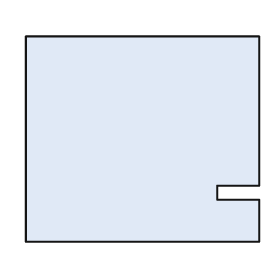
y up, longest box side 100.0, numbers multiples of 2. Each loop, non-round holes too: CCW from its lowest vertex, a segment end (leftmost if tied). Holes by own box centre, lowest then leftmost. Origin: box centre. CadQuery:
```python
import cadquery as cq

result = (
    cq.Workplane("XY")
    .moveTo(-50.0, -44.0)
    .lineTo(50.0, -44.0)
    .lineTo(50.0, -26.0)
    .lineTo(32.0, -26.0)
    .lineTo(32.0, -20.0)
    .lineTo(50.0, -20.0)
    .lineTo(50.0, 44.0)
    .lineTo(-50.0, 44.0)
    .close()
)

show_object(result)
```